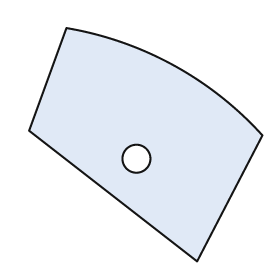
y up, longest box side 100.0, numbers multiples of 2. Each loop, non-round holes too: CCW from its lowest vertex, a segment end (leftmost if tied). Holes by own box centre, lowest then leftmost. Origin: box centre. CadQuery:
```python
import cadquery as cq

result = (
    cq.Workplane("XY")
    .moveTo(22.0, -50.0)
    .lineTo(50.0, 4.0)
    .threePointArc((12.0, 34.0), (-34.0, 50.0))
    .lineTo(-50.0, 6.0)
    .close()
    .moveTo(-4.0, -6.0)
    .circle(6.0)
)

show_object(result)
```